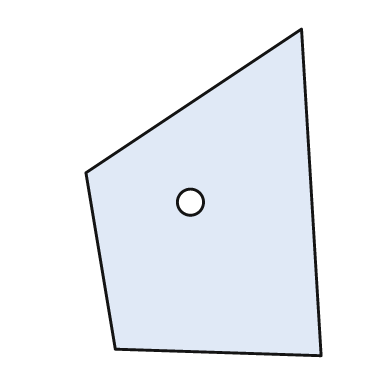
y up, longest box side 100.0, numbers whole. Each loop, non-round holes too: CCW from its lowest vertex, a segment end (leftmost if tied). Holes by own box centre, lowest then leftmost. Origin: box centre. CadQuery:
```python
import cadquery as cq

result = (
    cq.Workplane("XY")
    .moveTo(36.0, -50.0)
    .lineTo(30.0, 50.0)
    .lineTo(-36.0, 6.0)
    .lineTo(-27.0, -48.0)
    .close()
    .moveTo(-4.0, -3.0)
    .circle(4.0)
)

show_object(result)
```